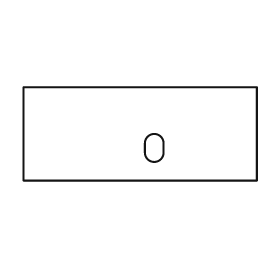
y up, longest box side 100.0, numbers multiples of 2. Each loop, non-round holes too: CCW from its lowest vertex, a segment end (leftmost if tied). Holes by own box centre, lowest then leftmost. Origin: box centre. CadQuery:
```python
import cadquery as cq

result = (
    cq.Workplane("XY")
    .moveTo(-50.0, -20.0)
    .lineTo(50.0, -20.0)
    .lineTo(50.0, 20.0)
    .lineTo(-50.0, 20.0)
    .close()
    .moveTo(2.0, -8.0)
    .threePointArc((6.0, -12.0), (10.0, -8.0))
    .lineTo(10.0, -4.0)
    .threePointArc((6.0, 0.0), (2.0, -4.0))
    .close()
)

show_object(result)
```